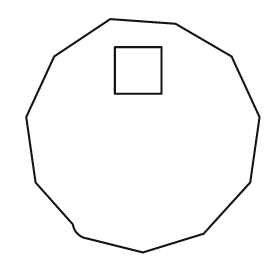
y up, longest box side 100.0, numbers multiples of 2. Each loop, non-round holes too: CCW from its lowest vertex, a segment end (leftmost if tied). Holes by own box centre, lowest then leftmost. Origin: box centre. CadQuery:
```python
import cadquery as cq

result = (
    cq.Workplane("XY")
    .moveTo(0.0, -50.0)
    .lineTo(26.0, -42.0)
    .lineTo(46.0, -20.0)
    .lineTo(50.0, 8.0)
    .lineTo(38.0, 34.0)
    .lineTo(14.0, 48.0)
    .lineTo(-14.0, 50.0)
    .lineTo(-38.0, 34.0)
    .lineTo(-50.0, 8.0)
    .lineTo(-46.0, -20.0)
    .lineTo(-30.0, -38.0)
    .threePointArc((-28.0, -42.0), (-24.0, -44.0))
    .close()
    .moveTo(-12.0, 18.0)
    .lineTo(8.0, 18.0)
    .lineTo(8.0, 38.0)
    .lineTo(-12.0, 38.0)
    .close()
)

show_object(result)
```